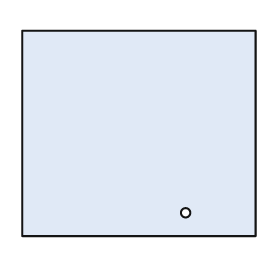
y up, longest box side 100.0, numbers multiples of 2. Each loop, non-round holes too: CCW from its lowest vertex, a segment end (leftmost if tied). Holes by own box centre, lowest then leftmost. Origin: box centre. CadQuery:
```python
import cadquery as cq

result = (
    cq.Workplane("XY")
    .moveTo(-50.0, -44.0)
    .lineTo(50.0, -44.0)
    .lineTo(50.0, 44.0)
    .lineTo(-50.0, 44.0)
    .close()
    .moveTo(20.0, -34.0)
    .circle(2.0)
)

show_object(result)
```